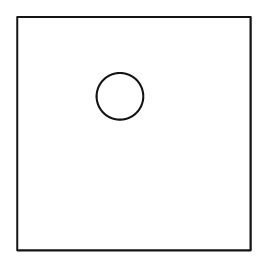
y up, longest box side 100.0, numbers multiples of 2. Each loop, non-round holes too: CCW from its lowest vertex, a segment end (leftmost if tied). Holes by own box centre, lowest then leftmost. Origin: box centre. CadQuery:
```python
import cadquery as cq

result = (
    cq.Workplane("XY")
    .moveTo(-50.0, -50.0)
    .lineTo(50.0, -50.0)
    .lineTo(50.0, 50.0)
    .lineTo(-50.0, 50.0)
    .close()
    .moveTo(-6.0, 16.0)
    .circle(10.0)
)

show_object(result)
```